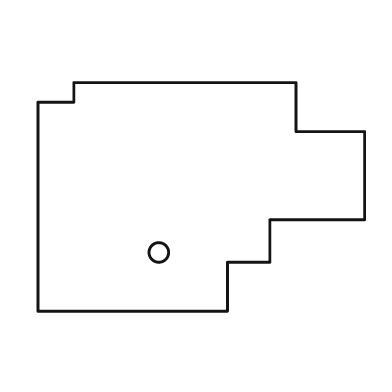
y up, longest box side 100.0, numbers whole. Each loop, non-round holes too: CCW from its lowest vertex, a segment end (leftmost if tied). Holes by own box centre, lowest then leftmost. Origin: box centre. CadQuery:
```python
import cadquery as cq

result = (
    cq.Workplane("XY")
    .moveTo(-50.0, -35.0)
    .lineTo(8.0, -35.0)
    .lineTo(8.0, -20.0)
    .lineTo(21.0, -20.0)
    .lineTo(21.0, -7.0)
    .lineTo(50.0, -7.0)
    .lineTo(50.0, 20.0)
    .lineTo(29.0, 20.0)
    .lineTo(29.0, 35.0)
    .lineTo(-39.0, 35.0)
    .lineTo(-39.0, 29.0)
    .lineTo(-50.0, 29.0)
    .close()
    .moveTo(-13.0, -17.0)
    .circle(3.0)
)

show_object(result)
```